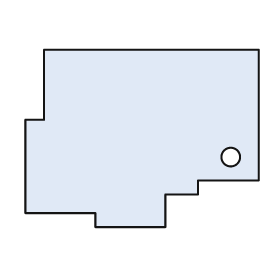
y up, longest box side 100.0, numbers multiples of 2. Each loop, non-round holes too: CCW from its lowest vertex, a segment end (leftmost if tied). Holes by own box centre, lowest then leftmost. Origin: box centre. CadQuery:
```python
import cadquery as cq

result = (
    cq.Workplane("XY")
    .moveTo(-20.0, -38.0)
    .lineTo(10.0, -38.0)
    .lineTo(10.0, -24.0)
    .lineTo(24.0, -24.0)
    .lineTo(24.0, -18.0)
    .lineTo(50.0, -18.0)
    .lineTo(50.0, 38.0)
    .lineTo(-42.0, 38.0)
    .lineTo(-42.0, 8.0)
    .lineTo(-50.0, 8.0)
    .lineTo(-50.0, -32.0)
    .lineTo(-20.0, -32.0)
    .close()
    .moveTo(38.0, -8.0)
    .circle(4.0)
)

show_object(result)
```